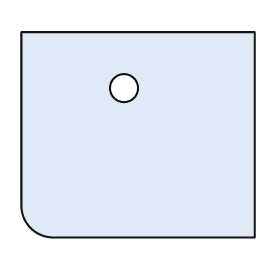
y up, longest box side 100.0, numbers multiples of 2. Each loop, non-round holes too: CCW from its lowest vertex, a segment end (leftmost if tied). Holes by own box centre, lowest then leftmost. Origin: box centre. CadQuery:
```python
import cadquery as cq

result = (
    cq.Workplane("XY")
    .moveTo(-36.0, -44.0)
    .lineTo(50.0, -44.0)
    .lineTo(50.0, 44.0)
    .lineTo(-50.0, 44.0)
    .lineTo(-50.0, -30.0)
    .threePointArc((-46.0, -40.0), (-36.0, -44.0))
    .close()
    .moveTo(-6.0, 20.0)
    .circle(6.0)
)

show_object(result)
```